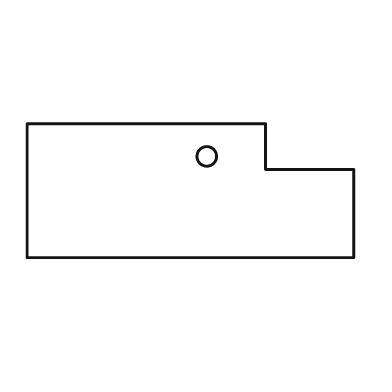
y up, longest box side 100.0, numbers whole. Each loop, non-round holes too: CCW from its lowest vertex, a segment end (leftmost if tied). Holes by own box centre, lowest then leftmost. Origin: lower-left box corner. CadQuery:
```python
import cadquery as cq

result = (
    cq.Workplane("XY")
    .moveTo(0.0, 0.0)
    .lineTo(100.0, 0.0)
    .lineTo(100.0, 27.0)
    .lineTo(73.0, 27.0)
    .lineTo(73.0, 41.0)
    .lineTo(0.0, 41.0)
    .close()
    .moveTo(55.0, 31.0)
    .circle(3.0)
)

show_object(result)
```